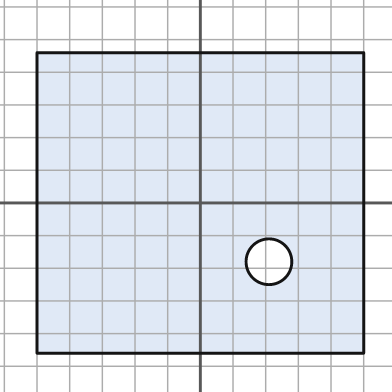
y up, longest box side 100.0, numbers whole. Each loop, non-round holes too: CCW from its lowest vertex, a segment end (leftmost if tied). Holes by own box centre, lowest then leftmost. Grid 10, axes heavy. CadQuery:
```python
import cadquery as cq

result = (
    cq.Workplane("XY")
    .moveTo(-50.0, -46.0)
    .lineTo(50.0, -46.0)
    .lineTo(50.0, 46.0)
    .lineTo(-50.0, 46.0)
    .close()
    .moveTo(21.0, -18.0)
    .circle(7.0)
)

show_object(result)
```